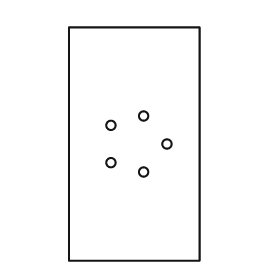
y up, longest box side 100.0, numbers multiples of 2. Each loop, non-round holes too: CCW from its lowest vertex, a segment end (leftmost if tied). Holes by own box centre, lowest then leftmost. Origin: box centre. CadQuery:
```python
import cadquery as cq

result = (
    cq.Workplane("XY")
    .moveTo(-28.0, -50.0)
    .lineTo(28.0, -50.0)
    .lineTo(28.0, 50.0)
    .lineTo(-28.0, 50.0)
    .close()
    .moveTo(4.0, -12.0)
    .circle(2.0)
    .moveTo(-10.0, -8.0)
    .circle(2.0)
    .moveTo(14.0, 0.0)
    .circle(2.0)
    .moveTo(-10.0, 8.0)
    .circle(2.0)
    .moveTo(4.0, 12.0)
    .circle(2.0)
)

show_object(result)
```